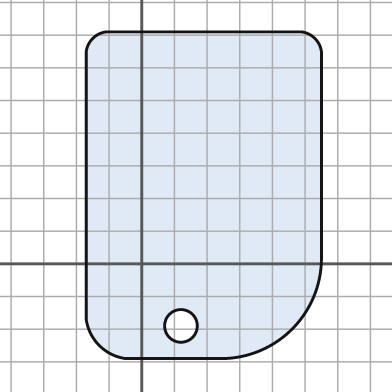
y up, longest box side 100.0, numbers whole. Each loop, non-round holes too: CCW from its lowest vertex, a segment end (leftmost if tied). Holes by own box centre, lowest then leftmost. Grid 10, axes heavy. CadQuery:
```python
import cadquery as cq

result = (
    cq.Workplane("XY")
    .moveTo(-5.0, -29.0)
    .lineTo(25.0, -29.0)
    .threePointArc((46.0, -20.0), (55.0, 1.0))
    .lineTo(55.0, 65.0)
    .threePointArc((53.0, 69.0), (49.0, 71.0))
    .lineTo(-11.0, 71.0)
    .threePointArc((-15.0, 69.0), (-17.0, 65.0))
    .lineTo(-17.0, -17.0)
    .threePointArc((-13.0, -25.0), (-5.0, -29.0))
    .close()
    .moveTo(12.0, -19.0)
    .circle(5.0)
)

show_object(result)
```